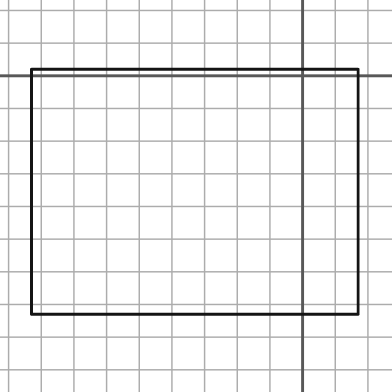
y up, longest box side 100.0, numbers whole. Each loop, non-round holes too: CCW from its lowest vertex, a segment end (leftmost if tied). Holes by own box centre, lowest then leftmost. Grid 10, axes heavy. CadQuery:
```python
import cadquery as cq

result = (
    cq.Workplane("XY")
    .moveTo(-83.0, -73.0)
    .lineTo(17.0, -73.0)
    .lineTo(17.0, 2.0)
    .lineTo(-83.0, 2.0)
    .close()
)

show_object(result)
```